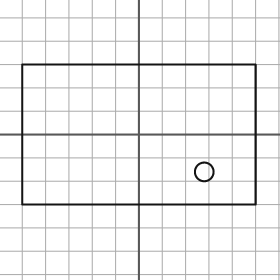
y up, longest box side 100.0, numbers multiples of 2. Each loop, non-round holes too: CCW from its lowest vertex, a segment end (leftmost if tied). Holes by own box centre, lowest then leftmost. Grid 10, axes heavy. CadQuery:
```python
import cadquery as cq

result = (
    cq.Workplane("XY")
    .moveTo(-50.0, -30.0)
    .lineTo(50.0, -30.0)
    .lineTo(50.0, 30.0)
    .lineTo(-50.0, 30.0)
    .close()
    .moveTo(28.0, -16.0)
    .circle(4.0)
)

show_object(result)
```